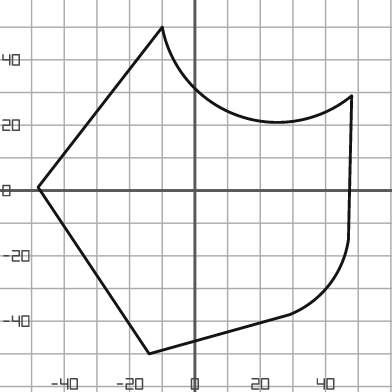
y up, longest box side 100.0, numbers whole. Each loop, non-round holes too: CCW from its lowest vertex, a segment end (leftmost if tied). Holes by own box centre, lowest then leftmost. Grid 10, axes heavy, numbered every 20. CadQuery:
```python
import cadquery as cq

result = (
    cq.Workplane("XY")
    .moveTo(-14.0, -50.0)
    .lineTo(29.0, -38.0)
    .threePointArc((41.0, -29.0), (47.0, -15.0))
    .lineTo(48.0, 29.0)
    .threePointArc((13.0, 23.0), (-10.0, 50.0))
    .lineTo(-48.0, 1.0)
    .close()
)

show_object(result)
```